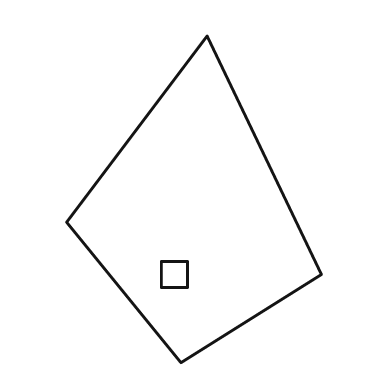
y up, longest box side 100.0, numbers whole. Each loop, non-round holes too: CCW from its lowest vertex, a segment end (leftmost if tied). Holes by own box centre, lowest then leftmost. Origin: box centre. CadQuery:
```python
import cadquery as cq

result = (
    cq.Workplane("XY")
    .moveTo(-4.0, -50.0)
    .lineTo(39.0, -23.0)
    .lineTo(4.0, 50.0)
    .lineTo(-39.0, -7.0)
    .close()
    .moveTo(-10.0, -27.0)
    .lineTo(-2.0, -27.0)
    .lineTo(-2.0, -19.0)
    .lineTo(-10.0, -19.0)
    .close()
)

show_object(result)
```